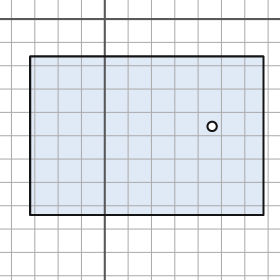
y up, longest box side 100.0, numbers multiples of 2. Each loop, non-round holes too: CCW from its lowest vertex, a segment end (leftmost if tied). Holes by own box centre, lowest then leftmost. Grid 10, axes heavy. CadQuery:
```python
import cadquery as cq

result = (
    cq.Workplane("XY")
    .moveTo(-32.0, -84.0)
    .lineTo(68.0, -84.0)
    .lineTo(68.0, -16.0)
    .lineTo(-32.0, -16.0)
    .close()
    .moveTo(46.0, -46.0)
    .circle(2.0)
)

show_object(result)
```